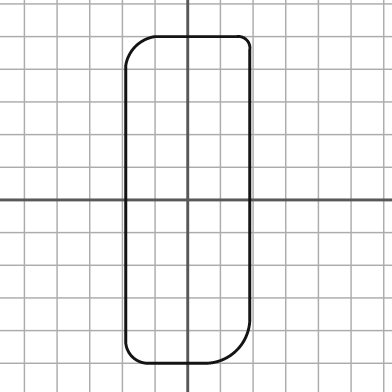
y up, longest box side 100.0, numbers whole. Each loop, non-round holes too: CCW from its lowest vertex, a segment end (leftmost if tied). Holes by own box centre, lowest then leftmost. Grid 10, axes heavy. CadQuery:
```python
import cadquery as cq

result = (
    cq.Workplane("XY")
    .moveTo(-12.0, -50.0)
    .lineTo(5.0, -50.0)
    .threePointArc((15.0, -46.0), (19.0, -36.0))
    .lineTo(19.0, 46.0)
    .threePointArc((18.0, 49.0), (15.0, 50.0))
    .lineTo(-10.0, 50.0)
    .threePointArc((-16.0, 47.0), (-19.0, 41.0))
    .lineTo(-19.0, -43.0)
    .threePointArc((-17.0, -48.0), (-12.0, -50.0))
    .close()
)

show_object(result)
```